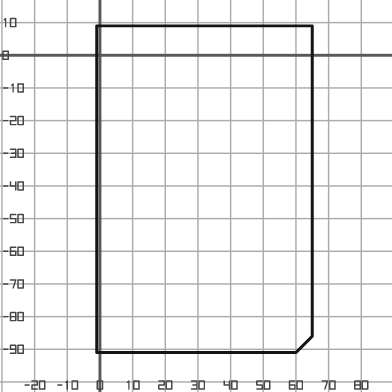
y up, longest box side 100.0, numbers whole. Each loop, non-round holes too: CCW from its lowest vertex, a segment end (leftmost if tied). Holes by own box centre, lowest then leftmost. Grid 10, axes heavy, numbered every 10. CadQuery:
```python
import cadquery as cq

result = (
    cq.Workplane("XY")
    .moveTo(-1.0, -91.0)
    .lineTo(60.0, -91.0)
    .lineTo(65.0, -86.0)
    .lineTo(65.0, 9.0)
    .lineTo(-1.0, 9.0)
    .close()
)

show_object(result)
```